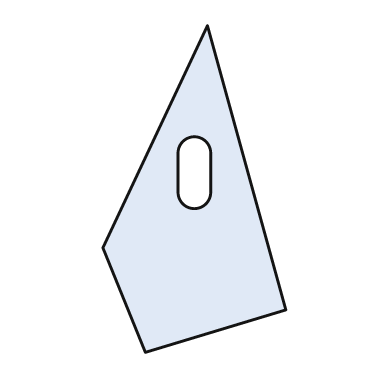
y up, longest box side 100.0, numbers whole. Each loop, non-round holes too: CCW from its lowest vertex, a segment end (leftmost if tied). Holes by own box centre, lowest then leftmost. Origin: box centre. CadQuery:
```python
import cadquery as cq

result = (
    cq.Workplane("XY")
    .moveTo(-15.0, -50.0)
    .lineTo(28.0, -37.0)
    .lineTo(4.0, 50.0)
    .lineTo(-28.0, -18.0)
    .close()
    .moveTo(-5.0, -1.0)
    .threePointArc((0.0, -6.0), (5.0, -1.0))
    .lineTo(5.0, 11.0)
    .threePointArc((0.0, 16.0), (-5.0, 11.0))
    .close()
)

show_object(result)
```